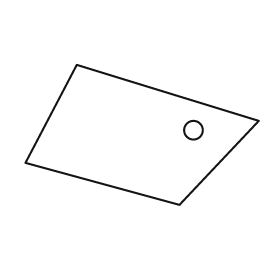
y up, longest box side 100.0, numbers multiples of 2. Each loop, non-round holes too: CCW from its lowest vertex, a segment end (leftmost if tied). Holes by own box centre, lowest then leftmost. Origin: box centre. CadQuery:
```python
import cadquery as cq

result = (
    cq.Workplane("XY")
    .moveTo(16.0, -30.0)
    .lineTo(50.0, 6.0)
    .lineTo(-28.0, 30.0)
    .lineTo(-50.0, -12.0)
    .close()
    .moveTo(22.0, 2.0)
    .circle(4.0)
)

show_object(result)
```